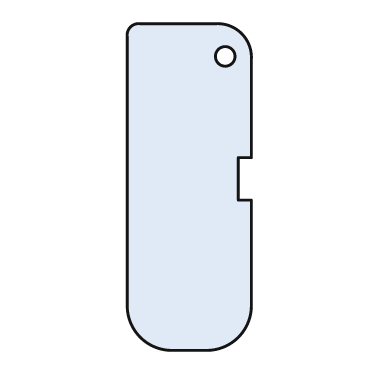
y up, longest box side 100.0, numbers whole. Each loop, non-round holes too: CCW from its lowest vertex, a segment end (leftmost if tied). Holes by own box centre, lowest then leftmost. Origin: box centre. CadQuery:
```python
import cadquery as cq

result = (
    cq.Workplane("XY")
    .moveTo(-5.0, -50.0)
    .lineTo(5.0, -50.0)
    .threePointArc((15.0, -46.0), (19.0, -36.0))
    .lineTo(19.0, -4.0)
    .lineTo(15.0, -4.0)
    .lineTo(15.0, 9.0)
    .lineTo(19.0, 9.0)
    .lineTo(19.0, 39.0)
    .threePointArc((16.0, 47.0), (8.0, 50.0))
    .lineTo(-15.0, 50.0)
    .threePointArc((-18.0, 49.0), (-19.0, 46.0))
    .lineTo(-19.0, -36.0)
    .threePointArc((-15.0, -46.0), (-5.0, -50.0))
    .close()
    .moveTo(11.0, 40.0)
    .circle(3.0)
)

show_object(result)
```